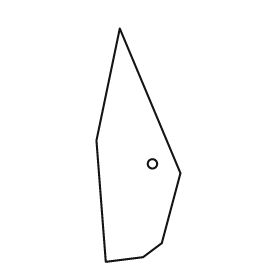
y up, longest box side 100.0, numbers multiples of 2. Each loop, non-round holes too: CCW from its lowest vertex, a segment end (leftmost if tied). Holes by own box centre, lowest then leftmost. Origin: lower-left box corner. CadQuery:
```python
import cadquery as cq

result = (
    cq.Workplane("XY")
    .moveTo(4.0, 0.0)
    .lineTo(20.0, 2.0)
    .lineTo(28.0, 8.0)
    .lineTo(36.0, 38.0)
    .lineTo(10.0, 100.0)
    .lineTo(0.0, 52.0)
    .close()
    .moveTo(24.0, 42.0)
    .circle(2.0)
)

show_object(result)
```